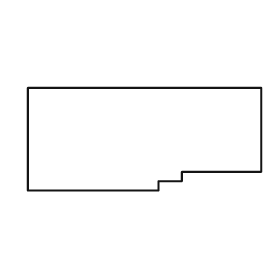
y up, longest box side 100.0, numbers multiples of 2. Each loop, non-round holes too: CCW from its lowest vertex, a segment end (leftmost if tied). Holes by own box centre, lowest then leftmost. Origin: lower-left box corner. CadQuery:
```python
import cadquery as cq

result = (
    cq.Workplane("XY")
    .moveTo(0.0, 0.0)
    .lineTo(56.0, 0.0)
    .lineTo(56.0, 4.0)
    .lineTo(66.0, 4.0)
    .lineTo(66.0, 8.0)
    .lineTo(100.0, 8.0)
    .lineTo(100.0, 44.0)
    .lineTo(0.0, 44.0)
    .close()
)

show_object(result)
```